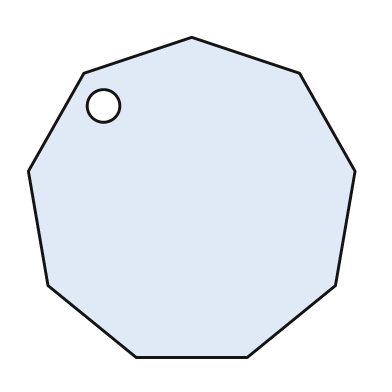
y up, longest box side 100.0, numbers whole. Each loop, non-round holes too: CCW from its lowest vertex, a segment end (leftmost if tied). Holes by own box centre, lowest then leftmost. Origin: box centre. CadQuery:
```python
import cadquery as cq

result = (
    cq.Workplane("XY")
    .moveTo(-17.0, -49.0)
    .lineTo(17.0, -49.0)
    .lineTo(44.0, -27.0)
    .lineTo(50.0, 8.0)
    .lineTo(33.0, 38.0)
    .lineTo(0.0, 49.0)
    .lineTo(-33.0, 38.0)
    .lineTo(-50.0, 8.0)
    .lineTo(-44.0, -27.0)
    .close()
    .moveTo(-27.0, 28.0)
    .circle(5.0)
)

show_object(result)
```